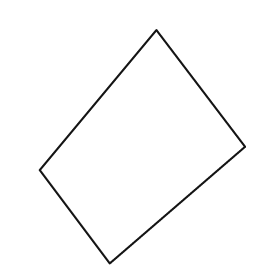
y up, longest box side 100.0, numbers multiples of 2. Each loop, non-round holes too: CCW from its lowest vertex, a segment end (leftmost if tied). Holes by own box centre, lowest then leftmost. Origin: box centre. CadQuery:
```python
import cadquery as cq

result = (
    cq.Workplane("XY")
    .moveTo(-14.0, -50.0)
    .lineTo(44.0, 0.0)
    .lineTo(6.0, 50.0)
    .lineTo(-44.0, -10.0)
    .close()
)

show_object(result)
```